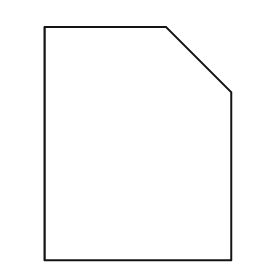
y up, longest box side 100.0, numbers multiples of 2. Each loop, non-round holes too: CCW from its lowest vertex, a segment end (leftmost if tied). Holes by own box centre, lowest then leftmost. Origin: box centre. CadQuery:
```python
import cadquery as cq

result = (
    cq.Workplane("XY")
    .moveTo(-40.0, -50.0)
    .lineTo(40.0, -50.0)
    .lineTo(40.0, 22.0)
    .lineTo(12.0, 50.0)
    .lineTo(-40.0, 50.0)
    .close()
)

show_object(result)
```